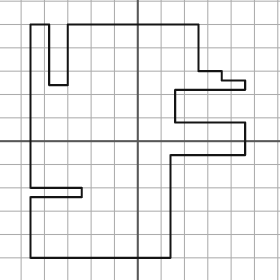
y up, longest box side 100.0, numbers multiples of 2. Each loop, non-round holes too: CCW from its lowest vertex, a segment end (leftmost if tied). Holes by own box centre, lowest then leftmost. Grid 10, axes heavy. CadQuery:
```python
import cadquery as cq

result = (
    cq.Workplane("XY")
    .moveTo(-46.0, -50.0)
    .lineTo(14.0, -50.0)
    .lineTo(14.0, -6.0)
    .lineTo(46.0, -6.0)
    .lineTo(46.0, 8.0)
    .lineTo(16.0, 8.0)
    .lineTo(16.0, 22.0)
    .lineTo(46.0, 22.0)
    .lineTo(46.0, 26.0)
    .lineTo(36.0, 26.0)
    .lineTo(36.0, 30.0)
    .lineTo(26.0, 30.0)
    .lineTo(26.0, 50.0)
    .lineTo(-30.0, 50.0)
    .lineTo(-30.0, 24.0)
    .lineTo(-38.0, 24.0)
    .lineTo(-38.0, 50.0)
    .lineTo(-46.0, 50.0)
    .lineTo(-46.0, -20.0)
    .lineTo(-24.0, -20.0)
    .lineTo(-24.0, -24.0)
    .lineTo(-46.0, -24.0)
    .close()
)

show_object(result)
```